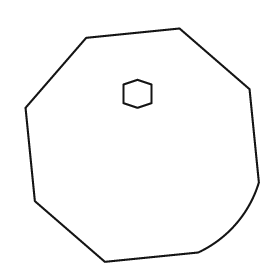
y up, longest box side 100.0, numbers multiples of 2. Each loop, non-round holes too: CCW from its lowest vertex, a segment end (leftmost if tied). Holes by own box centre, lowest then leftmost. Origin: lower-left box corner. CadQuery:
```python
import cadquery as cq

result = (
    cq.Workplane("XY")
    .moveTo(34.0, 0.0)
    .lineTo(74.0, 4.0)
    .threePointArc((90.0, 16.0), (100.0, 34.0))
    .lineTo(96.0, 74.0)
    .lineTo(66.0, 100.0)
    .lineTo(26.0, 96.0)
    .lineTo(0.0, 66.0)
    .lineTo(4.0, 26.0)
    .close()
    .moveTo(48.0, 66.0)
    .lineTo(54.0, 68.0)
    .lineTo(54.0, 76.0)
    .lineTo(48.0, 78.0)
    .lineTo(42.0, 76.0)
    .lineTo(42.0, 68.0)
    .close()
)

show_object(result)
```